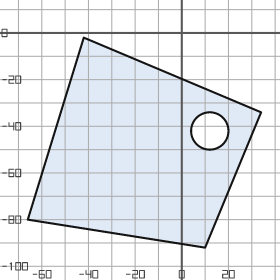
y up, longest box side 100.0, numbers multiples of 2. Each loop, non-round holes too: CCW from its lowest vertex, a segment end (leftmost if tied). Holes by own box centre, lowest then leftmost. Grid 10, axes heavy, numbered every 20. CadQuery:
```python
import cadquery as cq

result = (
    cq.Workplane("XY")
    .moveTo(10.0, -92.0)
    .lineTo(34.0, -34.0)
    .lineTo(-42.0, -2.0)
    .lineTo(-66.0, -80.0)
    .close()
    .moveTo(12.0, -42.0)
    .circle(8.0)
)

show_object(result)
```